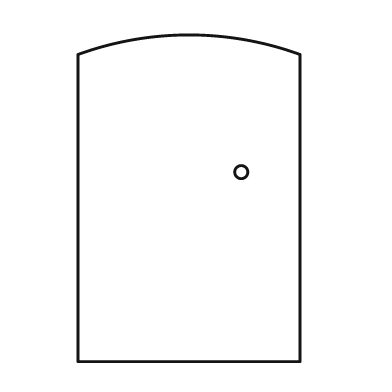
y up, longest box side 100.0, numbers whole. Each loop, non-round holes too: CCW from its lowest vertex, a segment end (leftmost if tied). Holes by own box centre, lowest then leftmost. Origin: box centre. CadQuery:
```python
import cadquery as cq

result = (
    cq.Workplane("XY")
    .moveTo(-34.0, -50.0)
    .lineTo(34.0, -50.0)
    .lineTo(34.0, 44.0)
    .threePointArc((0.0, 50.0), (-34.0, 44.0))
    .close()
    .moveTo(16.0, 8.0)
    .circle(2.0)
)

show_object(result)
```